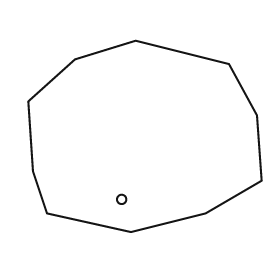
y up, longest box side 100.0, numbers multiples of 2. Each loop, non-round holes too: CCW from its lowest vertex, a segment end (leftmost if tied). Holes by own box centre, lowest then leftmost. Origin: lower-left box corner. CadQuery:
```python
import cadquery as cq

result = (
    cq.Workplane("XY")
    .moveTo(44.0, 0.0)
    .lineTo(76.0, 8.0)
    .lineTo(100.0, 22.0)
    .lineTo(98.0, 50.0)
    .lineTo(86.0, 72.0)
    .lineTo(46.0, 82.0)
    .lineTo(20.0, 74.0)
    .lineTo(0.0, 56.0)
    .lineTo(2.0, 26.0)
    .lineTo(8.0, 8.0)
    .close()
    .moveTo(40.0, 14.0)
    .circle(2.0)
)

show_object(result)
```